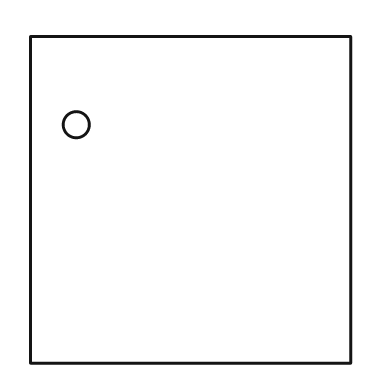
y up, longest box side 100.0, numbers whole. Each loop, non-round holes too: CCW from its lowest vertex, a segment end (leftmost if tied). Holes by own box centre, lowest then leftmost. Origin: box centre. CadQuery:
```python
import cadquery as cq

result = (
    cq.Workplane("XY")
    .moveTo(-49.0, -50.0)
    .lineTo(49.0, -50.0)
    .lineTo(49.0, 50.0)
    .lineTo(-49.0, 50.0)
    .close()
    .moveTo(-35.0, 23.0)
    .circle(4.0)
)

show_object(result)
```